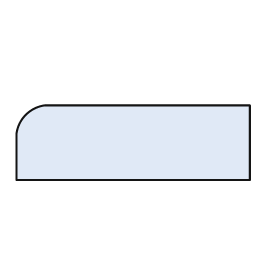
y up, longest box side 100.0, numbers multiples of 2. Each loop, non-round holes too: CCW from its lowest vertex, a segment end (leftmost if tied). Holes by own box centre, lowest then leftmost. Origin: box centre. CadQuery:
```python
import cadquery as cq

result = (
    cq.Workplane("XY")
    .moveTo(-50.0, -16.0)
    .lineTo(50.0, -16.0)
    .lineTo(50.0, 16.0)
    .lineTo(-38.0, 16.0)
    .threePointArc((-46.0, 12.0), (-50.0, 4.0))
    .close()
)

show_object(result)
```